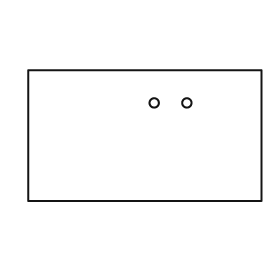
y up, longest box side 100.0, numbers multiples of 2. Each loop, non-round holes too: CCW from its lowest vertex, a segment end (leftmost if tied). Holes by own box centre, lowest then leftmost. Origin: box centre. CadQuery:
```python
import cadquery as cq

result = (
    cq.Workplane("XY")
    .moveTo(-50.0, -28.0)
    .lineTo(50.0, -28.0)
    .lineTo(50.0, 28.0)
    .lineTo(-50.0, 28.0)
    .close()
    .moveTo(4.0, 14.0)
    .circle(2.0)
    .moveTo(18.0, 14.0)
    .circle(2.0)
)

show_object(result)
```